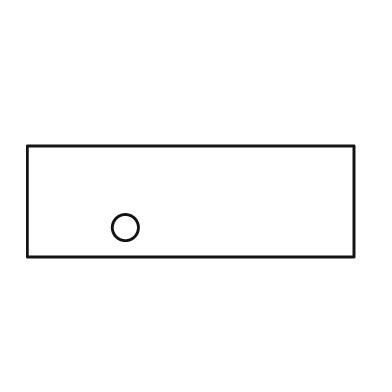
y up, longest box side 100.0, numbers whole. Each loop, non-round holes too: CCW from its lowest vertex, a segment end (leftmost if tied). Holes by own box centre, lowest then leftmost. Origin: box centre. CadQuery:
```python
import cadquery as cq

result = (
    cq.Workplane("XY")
    .moveTo(-50.0, -17.0)
    .lineTo(50.0, -17.0)
    .lineTo(50.0, 17.0)
    .lineTo(-50.0, 17.0)
    .close()
    .moveTo(-20.0, -8.0)
    .circle(4.0)
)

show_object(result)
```